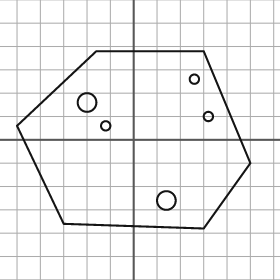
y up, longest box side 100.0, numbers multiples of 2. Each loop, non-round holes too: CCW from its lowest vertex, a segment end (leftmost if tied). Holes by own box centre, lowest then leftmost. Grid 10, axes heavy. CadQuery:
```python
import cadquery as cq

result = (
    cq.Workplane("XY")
    .moveTo(30.0, -38.0)
    .lineTo(50.0, -10.0)
    .lineTo(30.0, 38.0)
    .lineTo(-16.0, 38.0)
    .lineTo(-50.0, 6.0)
    .lineTo(-30.0, -36.0)
    .close()
    .moveTo(14.0, -26.0)
    .circle(4.0)
    .moveTo(-12.0, 6.0)
    .circle(2.0)
    .moveTo(32.0, 10.0)
    .circle(2.0)
    .moveTo(-20.0, 16.0)
    .circle(4.0)
    .moveTo(26.0, 26.0)
    .circle(2.0)
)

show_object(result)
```